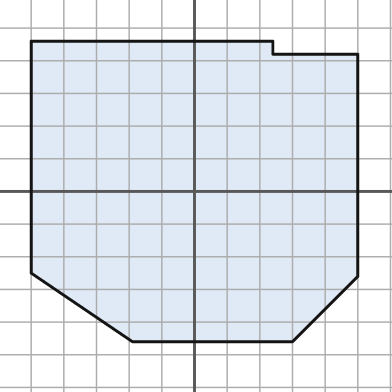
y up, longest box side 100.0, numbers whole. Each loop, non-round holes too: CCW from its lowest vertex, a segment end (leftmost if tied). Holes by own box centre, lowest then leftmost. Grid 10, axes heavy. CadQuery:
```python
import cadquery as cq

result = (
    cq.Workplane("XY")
    .moveTo(-19.0, -46.0)
    .lineTo(30.0, -46.0)
    .lineTo(50.0, -26.0)
    .lineTo(50.0, 42.0)
    .lineTo(24.0, 42.0)
    .lineTo(24.0, 46.0)
    .lineTo(-50.0, 46.0)
    .lineTo(-50.0, -25.0)
    .close()
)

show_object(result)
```